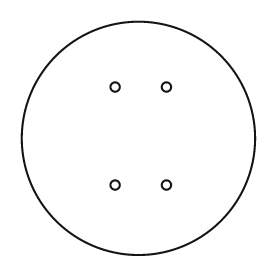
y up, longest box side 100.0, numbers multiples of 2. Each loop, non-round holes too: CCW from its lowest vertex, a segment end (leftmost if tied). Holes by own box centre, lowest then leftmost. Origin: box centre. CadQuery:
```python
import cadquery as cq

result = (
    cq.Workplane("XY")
    .moveTo(0.0, 0.0)
    .circle(50.0)
    .moveTo(-10.0, -20.0)
    .circle(2.0)
    .moveTo(12.0, -20.0)
    .circle(2.0)
    .moveTo(-10.0, 22.0)
    .circle(2.0)
    .moveTo(12.0, 22.0)
    .circle(2.0)
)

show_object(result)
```